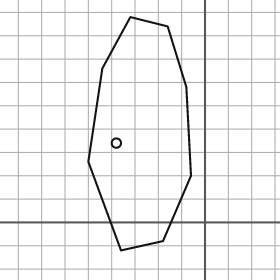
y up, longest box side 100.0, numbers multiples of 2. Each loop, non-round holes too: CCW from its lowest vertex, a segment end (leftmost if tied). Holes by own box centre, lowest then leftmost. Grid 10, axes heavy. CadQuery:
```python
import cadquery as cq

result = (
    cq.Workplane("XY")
    .moveTo(-36.0, -12.0)
    .lineTo(-18.0, -8.0)
    .lineTo(-6.0, 20.0)
    .lineTo(-8.0, 58.0)
    .lineTo(-16.0, 84.0)
    .lineTo(-32.0, 88.0)
    .lineTo(-44.0, 66.0)
    .lineTo(-50.0, 26.0)
    .close()
    .moveTo(-38.0, 34.0)
    .circle(2.0)
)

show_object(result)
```